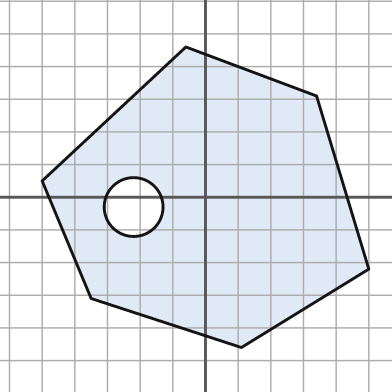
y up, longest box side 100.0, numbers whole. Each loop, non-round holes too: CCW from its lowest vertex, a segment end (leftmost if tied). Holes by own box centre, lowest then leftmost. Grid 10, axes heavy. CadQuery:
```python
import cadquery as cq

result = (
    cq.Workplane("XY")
    .moveTo(11.0, -46.0)
    .lineTo(50.0, -22.0)
    .lineTo(34.0, 31.0)
    .lineTo(-6.0, 46.0)
    .lineTo(-50.0, 5.0)
    .lineTo(-35.0, -31.0)
    .close()
    .moveTo(-22.0, -3.0)
    .circle(9.0)
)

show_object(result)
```